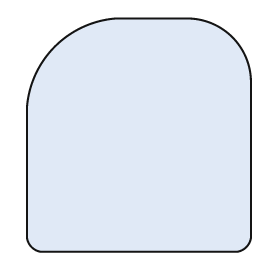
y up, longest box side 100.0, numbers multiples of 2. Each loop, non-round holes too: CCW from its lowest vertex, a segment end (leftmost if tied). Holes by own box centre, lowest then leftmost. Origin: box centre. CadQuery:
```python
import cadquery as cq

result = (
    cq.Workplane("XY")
    .moveTo(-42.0, -50.0)
    .lineTo(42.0, -50.0)
    .threePointArc((46.0, -48.0), (48.0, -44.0))
    .lineTo(48.0, 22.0)
    .threePointArc((40.0, 42.0), (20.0, 50.0))
    .lineTo(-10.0, 50.0)
    .threePointArc((-36.0, 38.0), (-48.0, 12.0))
    .lineTo(-48.0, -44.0)
    .threePointArc((-46.0, -48.0), (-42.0, -50.0))
    .close()
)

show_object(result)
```